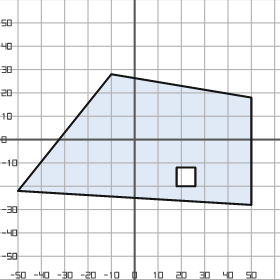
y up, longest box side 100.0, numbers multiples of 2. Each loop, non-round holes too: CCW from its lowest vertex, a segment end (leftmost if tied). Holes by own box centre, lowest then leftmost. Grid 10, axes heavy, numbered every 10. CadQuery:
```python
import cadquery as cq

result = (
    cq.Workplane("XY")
    .moveTo(50.0, -28.0)
    .lineTo(50.0, 18.0)
    .lineTo(-10.0, 28.0)
    .lineTo(-50.0, -22.0)
    .close()
    .moveTo(18.0, -20.0)
    .lineTo(26.0, -20.0)
    .lineTo(26.0, -12.0)
    .lineTo(18.0, -12.0)
    .close()
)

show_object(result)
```